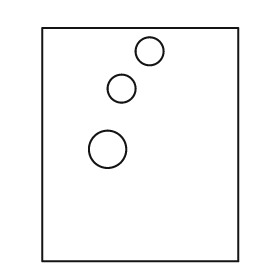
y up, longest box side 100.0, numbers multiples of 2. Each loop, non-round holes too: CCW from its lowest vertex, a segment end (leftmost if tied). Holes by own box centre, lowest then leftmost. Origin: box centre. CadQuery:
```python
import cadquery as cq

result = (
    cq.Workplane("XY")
    .moveTo(-42.0, -50.0)
    .lineTo(42.0, -50.0)
    .lineTo(42.0, 50.0)
    .lineTo(-42.0, 50.0)
    .close()
    .moveTo(-14.0, -2.0)
    .circle(8.0)
    .moveTo(-8.0, 24.0)
    .circle(6.0)
    .moveTo(4.0, 40.0)
    .circle(6.0)
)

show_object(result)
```